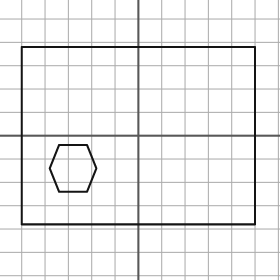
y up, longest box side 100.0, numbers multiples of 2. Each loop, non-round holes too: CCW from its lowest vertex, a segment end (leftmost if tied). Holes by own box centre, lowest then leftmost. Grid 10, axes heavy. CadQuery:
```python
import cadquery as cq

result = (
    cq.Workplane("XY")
    .moveTo(-50.0, -38.0)
    .lineTo(50.0, -38.0)
    .lineTo(50.0, 38.0)
    .lineTo(-50.0, 38.0)
    .close()
    .moveTo(-34.0, -24.0)
    .lineTo(-22.0, -24.0)
    .lineTo(-18.0, -14.0)
    .lineTo(-22.0, -4.0)
    .lineTo(-34.0, -4.0)
    .lineTo(-38.0, -14.0)
    .close()
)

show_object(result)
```